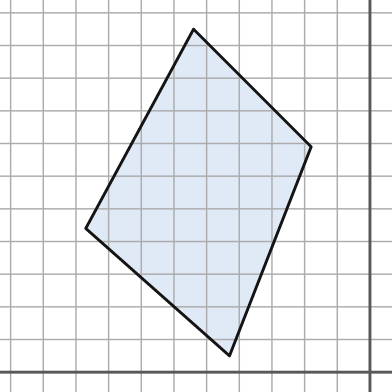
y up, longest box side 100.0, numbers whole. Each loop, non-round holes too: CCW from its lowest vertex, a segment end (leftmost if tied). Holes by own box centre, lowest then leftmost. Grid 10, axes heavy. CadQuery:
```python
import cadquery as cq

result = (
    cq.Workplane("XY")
    .moveTo(-43.0, 5.0)
    .lineTo(-18.0, 69.0)
    .lineTo(-54.0, 105.0)
    .lineTo(-87.0, 44.0)
    .close()
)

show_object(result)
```